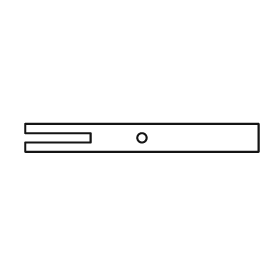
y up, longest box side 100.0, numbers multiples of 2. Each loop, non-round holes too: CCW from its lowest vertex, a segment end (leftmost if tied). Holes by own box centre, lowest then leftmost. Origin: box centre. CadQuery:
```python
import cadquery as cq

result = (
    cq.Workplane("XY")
    .moveTo(-50.0, -6.0)
    .lineTo(50.0, -6.0)
    .lineTo(50.0, 6.0)
    .lineTo(-50.0, 6.0)
    .lineTo(-50.0, 2.0)
    .lineTo(-22.0, 2.0)
    .lineTo(-22.0, -2.0)
    .lineTo(-50.0, -2.0)
    .close()
    .moveTo(0.0, 0.0)
    .circle(2.0)
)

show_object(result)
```